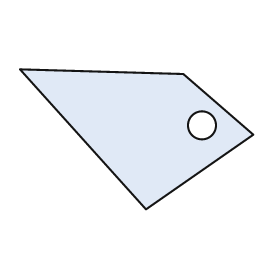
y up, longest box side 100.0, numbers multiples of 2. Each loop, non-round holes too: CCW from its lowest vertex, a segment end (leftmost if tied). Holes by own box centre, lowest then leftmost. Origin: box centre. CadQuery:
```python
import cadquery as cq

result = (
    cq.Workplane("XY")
    .moveTo(4.0, -30.0)
    .lineTo(50.0, 2.0)
    .lineTo(20.0, 28.0)
    .lineTo(-50.0, 30.0)
    .close()
    .moveTo(28.0, 6.0)
    .circle(6.0)
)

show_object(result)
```